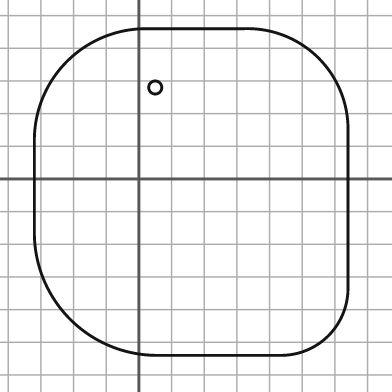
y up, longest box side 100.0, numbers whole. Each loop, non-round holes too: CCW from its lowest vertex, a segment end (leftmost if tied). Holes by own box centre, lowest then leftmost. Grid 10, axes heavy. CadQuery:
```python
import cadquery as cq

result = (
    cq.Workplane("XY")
    .moveTo(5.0, -54.0)
    .lineTo(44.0, -54.0)
    .threePointArc((58.0, -48.0), (64.0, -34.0))
    .lineTo(64.0, 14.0)
    .threePointArc((55.0, 37.0), (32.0, 46.0))
    .lineTo(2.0, 46.0)
    .threePointArc((-22.0, 36.0), (-32.0, 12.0))
    .lineTo(-32.0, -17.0)
    .threePointArc((-21.0, -43.0), (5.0, -54.0))
    .close()
    .moveTo(5.0, 28.0)
    .circle(2.0)
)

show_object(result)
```